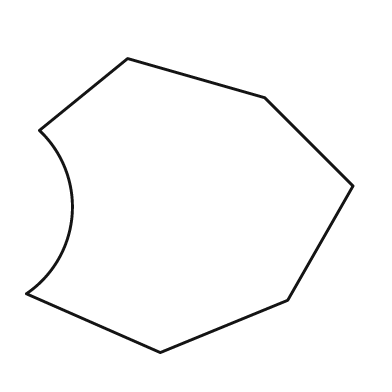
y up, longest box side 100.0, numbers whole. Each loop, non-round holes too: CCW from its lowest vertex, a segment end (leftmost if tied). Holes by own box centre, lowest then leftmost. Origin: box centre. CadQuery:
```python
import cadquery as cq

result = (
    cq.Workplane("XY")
    .moveTo(-9.0, -45.0)
    .lineTo(30.0, -29.0)
    .lineTo(50.0, 6.0)
    .lineTo(23.0, 33.0)
    .lineTo(-19.0, 45.0)
    .lineTo(-46.0, 23.0)
    .threePointArc((-36.0, -3.0), (-50.0, -27.0))
    .close()
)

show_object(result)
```